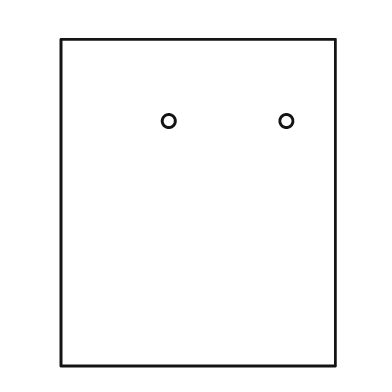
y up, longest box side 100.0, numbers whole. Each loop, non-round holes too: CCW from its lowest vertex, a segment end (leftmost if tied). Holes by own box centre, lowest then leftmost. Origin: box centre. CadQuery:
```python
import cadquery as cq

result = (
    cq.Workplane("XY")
    .moveTo(-42.0, -50.0)
    .lineTo(42.0, -50.0)
    .lineTo(42.0, 50.0)
    .lineTo(-42.0, 50.0)
    .close()
    .moveTo(-9.0, 25.0)
    .circle(2.0)
    .moveTo(27.0, 25.0)
    .circle(2.0)
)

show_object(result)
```